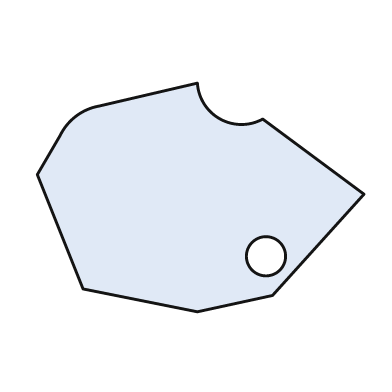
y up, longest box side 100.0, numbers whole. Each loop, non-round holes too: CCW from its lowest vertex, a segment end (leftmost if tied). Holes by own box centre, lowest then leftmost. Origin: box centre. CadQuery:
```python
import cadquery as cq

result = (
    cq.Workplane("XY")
    .moveTo(-1.0, -35.0)
    .lineTo(22.0, -30.0)
    .lineTo(50.0, 1.0)
    .lineTo(19.0, 24.0)
    .threePointArc((6.0, 24.0), (-1.0, 35.0))
    .lineTo(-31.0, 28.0)
    .threePointArc((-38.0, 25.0), (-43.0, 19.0))
    .lineTo(-50.0, 7.0)
    .lineTo(-36.0, -28.0)
    .close()
    .moveTo(20.0, -18.0)
    .circle(6.0)
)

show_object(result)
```